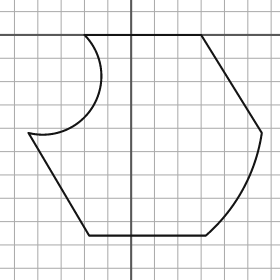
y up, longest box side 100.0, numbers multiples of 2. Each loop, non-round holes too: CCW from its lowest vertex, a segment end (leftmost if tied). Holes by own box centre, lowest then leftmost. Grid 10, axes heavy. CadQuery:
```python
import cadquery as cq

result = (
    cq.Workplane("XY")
    .moveTo(-18.0, -86.0)
    .lineTo(32.0, -86.0)
    .threePointArc((48.0, -66.0), (56.0, -42.0))
    .lineTo(30.0, 0.0)
    .lineTo(-20.0, 0.0)
    .threePointArc((-16.0, -30.0), (-44.0, -42.0))
    .close()
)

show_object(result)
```